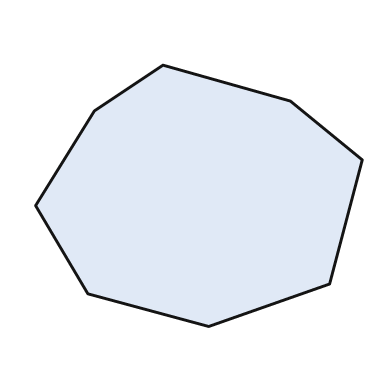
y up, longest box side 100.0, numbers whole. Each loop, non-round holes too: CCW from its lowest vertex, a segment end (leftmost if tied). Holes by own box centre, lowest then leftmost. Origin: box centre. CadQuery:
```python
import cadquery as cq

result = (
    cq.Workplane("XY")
    .moveTo(3.0, -40.0)
    .lineTo(40.0, -27.0)
    .lineTo(50.0, 11.0)
    .lineTo(28.0, 29.0)
    .lineTo(-11.0, 40.0)
    .lineTo(-32.0, 26.0)
    .lineTo(-50.0, -3.0)
    .lineTo(-34.0, -30.0)
    .close()
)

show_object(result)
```